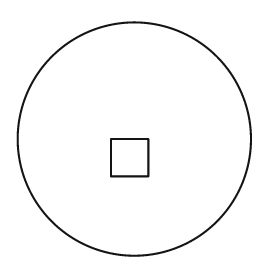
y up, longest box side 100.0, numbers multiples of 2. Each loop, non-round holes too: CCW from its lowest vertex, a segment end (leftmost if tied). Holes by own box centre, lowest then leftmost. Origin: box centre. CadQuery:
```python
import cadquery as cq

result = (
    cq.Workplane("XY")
    .moveTo(0.0, 0.0)
    .circle(50.0)
    .moveTo(-10.0, -16.0)
    .lineTo(6.0, -16.0)
    .lineTo(6.0, 0.0)
    .lineTo(-10.0, 0.0)
    .close()
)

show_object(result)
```